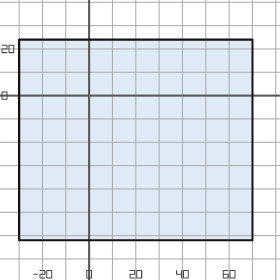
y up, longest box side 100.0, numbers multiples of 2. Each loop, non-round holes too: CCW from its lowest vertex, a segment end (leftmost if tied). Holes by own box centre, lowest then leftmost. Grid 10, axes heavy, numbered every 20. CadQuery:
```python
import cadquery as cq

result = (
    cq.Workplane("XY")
    .moveTo(-30.0, -62.0)
    .lineTo(70.0, -62.0)
    .lineTo(70.0, 24.0)
    .lineTo(-30.0, 24.0)
    .close()
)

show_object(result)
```